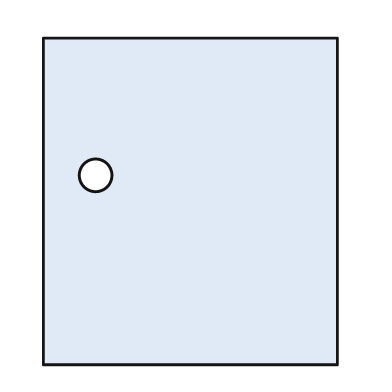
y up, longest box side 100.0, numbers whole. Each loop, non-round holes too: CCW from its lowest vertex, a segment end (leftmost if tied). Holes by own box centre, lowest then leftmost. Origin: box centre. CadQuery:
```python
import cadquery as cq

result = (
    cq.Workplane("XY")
    .moveTo(-45.0, -50.0)
    .lineTo(45.0, -50.0)
    .lineTo(45.0, 50.0)
    .lineTo(-45.0, 50.0)
    .close()
    .moveTo(-29.0, 8.0)
    .circle(5.0)
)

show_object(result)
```